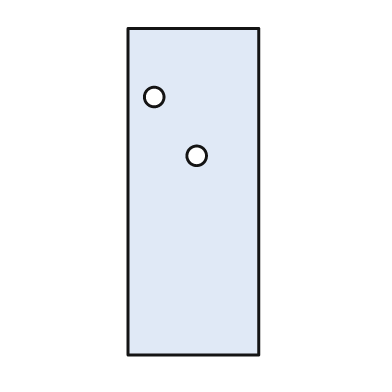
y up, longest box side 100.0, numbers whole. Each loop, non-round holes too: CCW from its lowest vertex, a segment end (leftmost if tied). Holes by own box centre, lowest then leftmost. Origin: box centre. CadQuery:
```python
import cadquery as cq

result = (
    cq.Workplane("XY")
    .moveTo(-20.0, -50.0)
    .lineTo(20.0, -50.0)
    .lineTo(20.0, 50.0)
    .lineTo(-20.0, 50.0)
    .close()
    .moveTo(1.0, 11.0)
    .circle(3.0)
    .moveTo(-12.0, 29.0)
    .circle(3.0)
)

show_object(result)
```